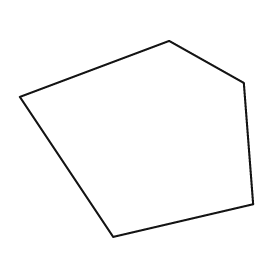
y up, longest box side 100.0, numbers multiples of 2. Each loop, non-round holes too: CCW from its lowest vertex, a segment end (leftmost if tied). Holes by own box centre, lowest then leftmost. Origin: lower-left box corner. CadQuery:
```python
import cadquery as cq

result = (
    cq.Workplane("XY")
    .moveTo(40.0, 0.0)
    .lineTo(100.0, 14.0)
    .lineTo(96.0, 66.0)
    .lineTo(64.0, 84.0)
    .lineTo(0.0, 60.0)
    .close()
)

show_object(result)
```